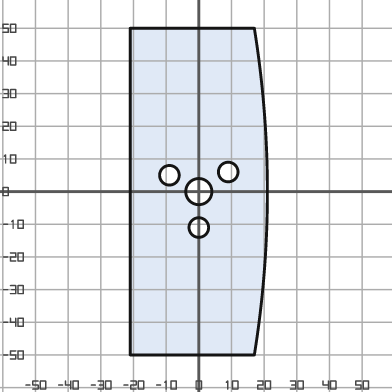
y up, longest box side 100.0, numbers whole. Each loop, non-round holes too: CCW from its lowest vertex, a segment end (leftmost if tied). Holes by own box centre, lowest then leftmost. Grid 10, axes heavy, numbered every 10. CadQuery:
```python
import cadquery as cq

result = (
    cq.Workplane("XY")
    .moveTo(-21.0, -50.0)
    .lineTo(17.0, -50.0)
    .threePointArc((21.0, 0.0), (17.0, 50.0))
    .lineTo(-21.0, 50.0)
    .close()
    .moveTo(0.0, -11.0)
    .circle(3.0)
    .moveTo(0.0, 0.0)
    .circle(4.0)
    .moveTo(-9.0, 5.0)
    .circle(3.0)
    .moveTo(9.0, 6.0)
    .circle(3.0)
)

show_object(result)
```